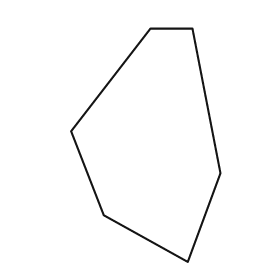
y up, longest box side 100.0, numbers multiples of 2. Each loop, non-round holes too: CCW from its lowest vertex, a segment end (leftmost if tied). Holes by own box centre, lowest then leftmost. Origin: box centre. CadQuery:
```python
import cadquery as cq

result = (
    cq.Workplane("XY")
    .moveTo(18.0, -50.0)
    .lineTo(32.0, -12.0)
    .lineTo(20.0, 50.0)
    .lineTo(2.0, 50.0)
    .lineTo(-32.0, 6.0)
    .lineTo(-18.0, -30.0)
    .close()
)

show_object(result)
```